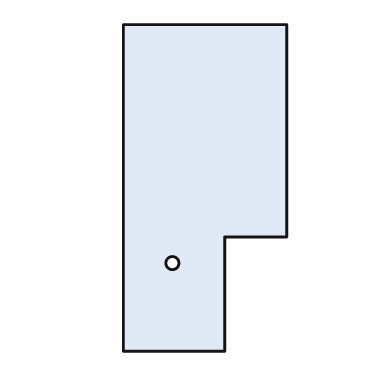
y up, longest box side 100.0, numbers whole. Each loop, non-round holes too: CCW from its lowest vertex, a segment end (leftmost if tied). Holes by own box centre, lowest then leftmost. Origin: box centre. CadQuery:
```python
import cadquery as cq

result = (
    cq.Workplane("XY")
    .moveTo(-25.0, -50.0)
    .lineTo(6.0, -50.0)
    .lineTo(6.0, -15.0)
    .lineTo(25.0, -15.0)
    .lineTo(25.0, 50.0)
    .lineTo(-25.0, 50.0)
    .close()
    .moveTo(-10.0, -23.0)
    .circle(2.0)
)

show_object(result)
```